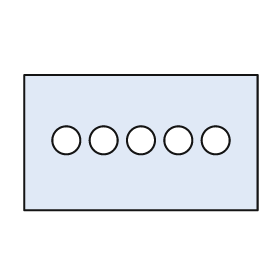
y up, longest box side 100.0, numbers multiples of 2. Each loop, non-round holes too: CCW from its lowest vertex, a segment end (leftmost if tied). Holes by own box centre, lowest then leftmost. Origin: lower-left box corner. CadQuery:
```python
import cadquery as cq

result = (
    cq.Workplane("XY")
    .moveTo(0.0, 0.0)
    .lineTo(100.0, 0.0)
    .lineTo(100.0, 58.0)
    .lineTo(0.0, 58.0)
    .close()
    .moveTo(18.0, 30.0)
    .circle(6.0)
    .moveTo(34.0, 30.0)
    .circle(6.0)
    .moveTo(50.0, 30.0)
    .circle(6.0)
    .moveTo(66.0, 30.0)
    .circle(6.0)
    .moveTo(82.0, 30.0)
    .circle(6.0)
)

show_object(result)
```